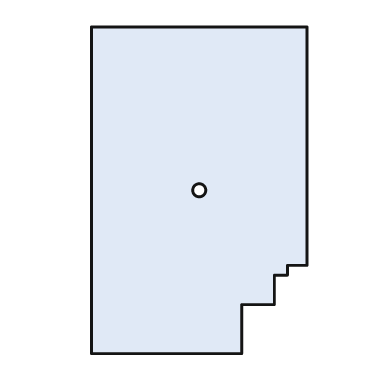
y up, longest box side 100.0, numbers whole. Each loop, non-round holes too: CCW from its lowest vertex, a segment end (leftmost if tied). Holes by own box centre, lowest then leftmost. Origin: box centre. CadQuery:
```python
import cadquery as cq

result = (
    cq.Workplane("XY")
    .moveTo(-33.0, -50.0)
    .lineTo(13.0, -50.0)
    .lineTo(13.0, -35.0)
    .lineTo(23.0, -35.0)
    .lineTo(23.0, -26.0)
    .lineTo(27.0, -26.0)
    .lineTo(27.0, -23.0)
    .lineTo(33.0, -23.0)
    .lineTo(33.0, 50.0)
    .lineTo(-33.0, 50.0)
    .close()
    .moveTo(0.0, 0.0)
    .circle(2.0)
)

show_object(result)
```